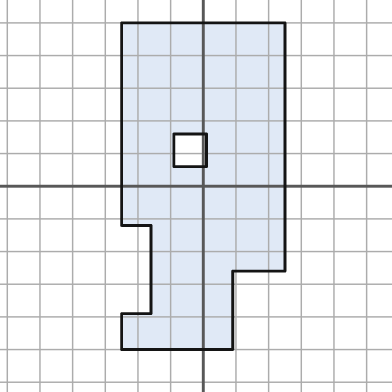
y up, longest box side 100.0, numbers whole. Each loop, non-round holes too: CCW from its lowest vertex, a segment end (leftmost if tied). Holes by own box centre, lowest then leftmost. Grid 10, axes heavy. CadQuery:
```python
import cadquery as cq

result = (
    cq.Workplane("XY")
    .moveTo(-25.0, -50.0)
    .lineTo(9.0, -50.0)
    .lineTo(9.0, -26.0)
    .lineTo(25.0, -26.0)
    .lineTo(25.0, 50.0)
    .lineTo(-25.0, 50.0)
    .lineTo(-25.0, -12.0)
    .lineTo(-16.0, -12.0)
    .lineTo(-16.0, -39.0)
    .lineTo(-25.0, -39.0)
    .close()
    .moveTo(-9.0, 6.0)
    .lineTo(1.0, 6.0)
    .lineTo(1.0, 16.0)
    .lineTo(-9.0, 16.0)
    .close()
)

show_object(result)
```